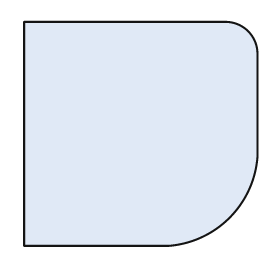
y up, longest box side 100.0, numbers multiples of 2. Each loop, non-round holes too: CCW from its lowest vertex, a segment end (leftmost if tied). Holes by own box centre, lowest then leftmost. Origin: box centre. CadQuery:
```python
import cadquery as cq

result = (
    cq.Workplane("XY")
    .moveTo(-50.0, -48.0)
    .lineTo(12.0, -48.0)
    .threePointArc((38.0, -36.0), (50.0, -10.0))
    .lineTo(50.0, 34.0)
    .threePointArc((46.0, 44.0), (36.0, 48.0))
    .lineTo(-50.0, 48.0)
    .close()
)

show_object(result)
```